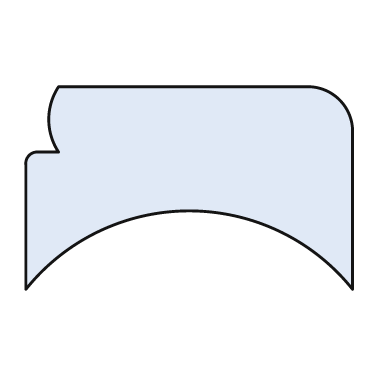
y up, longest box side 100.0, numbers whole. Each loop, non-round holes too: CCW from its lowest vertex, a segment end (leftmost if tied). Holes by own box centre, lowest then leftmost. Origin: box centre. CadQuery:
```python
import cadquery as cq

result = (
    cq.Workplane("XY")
    .moveTo(-50.0, -31.0)
    .threePointArc((0.0, -7.0), (50.0, -31.0))
    .lineTo(50.0, 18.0)
    .threePointArc((46.0, 27.0), (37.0, 31.0))
    .lineTo(-40.0, 31.0)
    .threePointArc((-43.0, 21.0), (-40.0, 11.0))
    .lineTo(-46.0, 11.0)
    .threePointArc((-49.0, 10.0), (-50.0, 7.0))
    .close()
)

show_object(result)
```